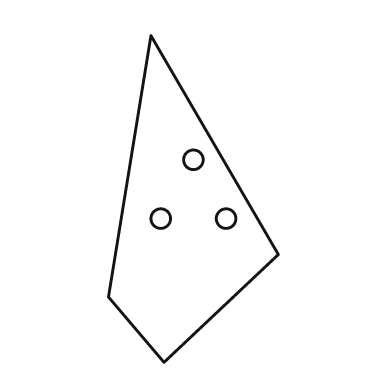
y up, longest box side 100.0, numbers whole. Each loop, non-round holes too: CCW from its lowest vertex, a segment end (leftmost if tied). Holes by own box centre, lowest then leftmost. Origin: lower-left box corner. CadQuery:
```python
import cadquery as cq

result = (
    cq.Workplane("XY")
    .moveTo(17.0, 0.0)
    .lineTo(52.0, 33.0)
    .lineTo(13.0, 100.0)
    .lineTo(0.0, 20.0)
    .close()
    .moveTo(16.0, 44.0)
    .circle(3.0)
    .moveTo(36.0, 44.0)
    .circle(3.0)
    .moveTo(26.0, 62.0)
    .circle(3.0)
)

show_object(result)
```